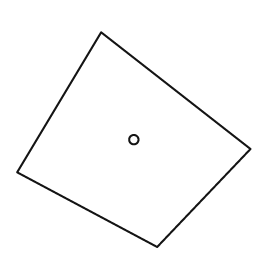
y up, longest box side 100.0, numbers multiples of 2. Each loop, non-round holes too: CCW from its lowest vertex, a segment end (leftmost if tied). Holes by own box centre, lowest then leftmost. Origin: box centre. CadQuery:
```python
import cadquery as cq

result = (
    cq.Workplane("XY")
    .moveTo(10.0, -46.0)
    .lineTo(50.0, -4.0)
    .lineTo(-14.0, 46.0)
    .lineTo(-50.0, -14.0)
    .close()
    .moveTo(0.0, 0.0)
    .circle(2.0)
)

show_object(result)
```